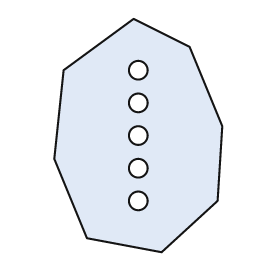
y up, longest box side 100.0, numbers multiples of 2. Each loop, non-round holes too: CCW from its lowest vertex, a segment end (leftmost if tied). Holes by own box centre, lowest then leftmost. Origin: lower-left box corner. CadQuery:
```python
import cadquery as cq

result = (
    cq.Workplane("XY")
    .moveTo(46.0, 0.0)
    .lineTo(70.0, 22.0)
    .lineTo(72.0, 54.0)
    .lineTo(58.0, 88.0)
    .lineTo(34.0, 100.0)
    .lineTo(4.0, 78.0)
    .lineTo(0.0, 40.0)
    .lineTo(14.0, 6.0)
    .close()
    .moveTo(36.0, 22.0)
    .circle(4.0)
    .moveTo(36.0, 36.0)
    .circle(4.0)
    .moveTo(36.0, 50.0)
    .circle(4.0)
    .moveTo(36.0, 64.0)
    .circle(4.0)
    .moveTo(36.0, 78.0)
    .circle(4.0)
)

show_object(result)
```